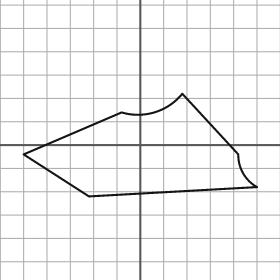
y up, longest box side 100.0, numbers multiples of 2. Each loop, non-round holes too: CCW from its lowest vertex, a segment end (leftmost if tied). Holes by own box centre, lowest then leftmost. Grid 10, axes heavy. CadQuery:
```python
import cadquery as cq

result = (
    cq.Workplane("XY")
    .moveTo(-22.0, -22.0)
    .lineTo(50.0, -18.0)
    .threePointArc((44.0, -12.0), (42.0, -4.0))
    .lineTo(18.0, 22.0)
    .threePointArc((6.0, 14.0), (-8.0, 14.0))
    .lineTo(-50.0, -4.0)
    .close()
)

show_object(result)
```